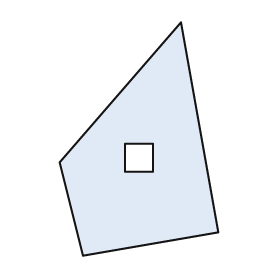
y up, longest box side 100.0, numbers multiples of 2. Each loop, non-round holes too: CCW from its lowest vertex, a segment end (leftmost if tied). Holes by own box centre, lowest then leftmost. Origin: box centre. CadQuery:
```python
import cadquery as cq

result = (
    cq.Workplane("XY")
    .moveTo(-24.0, -50.0)
    .lineTo(34.0, -40.0)
    .lineTo(18.0, 50.0)
    .lineTo(-34.0, -10.0)
    .close()
    .moveTo(-6.0, -14.0)
    .lineTo(6.0, -14.0)
    .lineTo(6.0, -2.0)
    .lineTo(-6.0, -2.0)
    .close()
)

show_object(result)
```